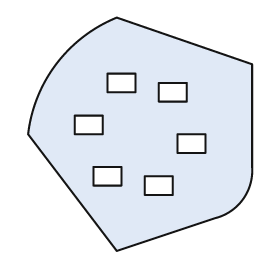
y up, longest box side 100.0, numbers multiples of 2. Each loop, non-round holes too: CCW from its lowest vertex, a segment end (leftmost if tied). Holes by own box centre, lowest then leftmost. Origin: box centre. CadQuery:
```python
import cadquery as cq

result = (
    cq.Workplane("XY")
    .moveTo(-10.0, -50.0)
    .lineTo(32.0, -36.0)
    .threePointArc((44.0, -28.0), (48.0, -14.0))
    .lineTo(48.0, 30.0)
    .lineTo(-10.0, 50.0)
    .threePointArc((-36.0, 30.0), (-48.0, 0.0))
    .close()
    .moveTo(2.0, -26.0)
    .lineTo(14.0, -26.0)
    .lineTo(14.0, -18.0)
    .lineTo(2.0, -18.0)
    .close()
    .moveTo(-20.0, -22.0)
    .lineTo(-8.0, -22.0)
    .lineTo(-8.0, -14.0)
    .lineTo(-20.0, -14.0)
    .close()
    .moveTo(16.0, -8.0)
    .lineTo(28.0, -8.0)
    .lineTo(28.0, 0.0)
    .lineTo(16.0, 0.0)
    .close()
    .moveTo(-28.0, 0.0)
    .lineTo(-16.0, 0.0)
    .lineTo(-16.0, 8.0)
    .lineTo(-28.0, 8.0)
    .close()
    .moveTo(8.0, 14.0)
    .lineTo(20.0, 14.0)
    .lineTo(20.0, 22.0)
    .lineTo(8.0, 22.0)
    .close()
    .moveTo(-14.0, 18.0)
    .lineTo(-2.0, 18.0)
    .lineTo(-2.0, 26.0)
    .lineTo(-14.0, 26.0)
    .close()
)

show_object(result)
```